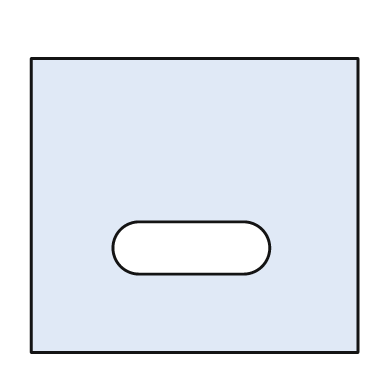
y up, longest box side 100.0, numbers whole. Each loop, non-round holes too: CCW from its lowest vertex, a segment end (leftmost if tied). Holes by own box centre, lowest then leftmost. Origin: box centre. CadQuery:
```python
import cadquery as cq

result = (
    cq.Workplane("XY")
    .moveTo(-50.0, -45.0)
    .lineTo(50.0, -45.0)
    .lineTo(50.0, 45.0)
    .lineTo(-50.0, 45.0)
    .close()
    .moveTo(-17.0, -21.0)
    .lineTo(15.0, -21.0)
    .threePointArc((23.0, -13.0), (15.0, -5.0))
    .lineTo(-17.0, -5.0)
    .threePointArc((-25.0, -13.0), (-17.0, -21.0))
    .close()
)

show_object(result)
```